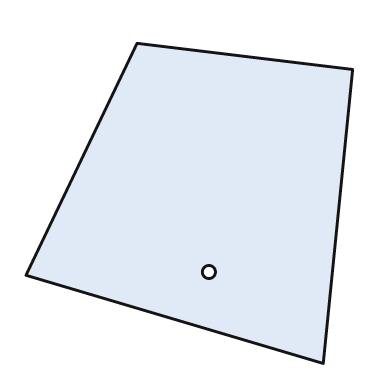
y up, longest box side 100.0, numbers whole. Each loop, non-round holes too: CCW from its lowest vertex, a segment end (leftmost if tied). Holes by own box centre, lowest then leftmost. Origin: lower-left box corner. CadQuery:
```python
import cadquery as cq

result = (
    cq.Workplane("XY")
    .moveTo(91.0, 0.0)
    .lineTo(100.0, 90.0)
    .lineTo(34.0, 98.0)
    .lineTo(0.0, 27.0)
    .close()
    .moveTo(56.0, 28.0)
    .circle(2.0)
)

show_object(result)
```